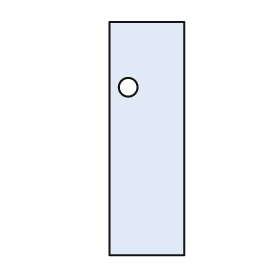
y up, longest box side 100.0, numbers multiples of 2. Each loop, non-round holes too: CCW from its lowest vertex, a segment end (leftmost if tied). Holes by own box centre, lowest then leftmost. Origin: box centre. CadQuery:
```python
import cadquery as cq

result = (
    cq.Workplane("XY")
    .moveTo(-16.0, -50.0)
    .lineTo(16.0, -50.0)
    .lineTo(16.0, 50.0)
    .lineTo(-16.0, 50.0)
    .close()
    .moveTo(-8.0, 22.0)
    .circle(4.0)
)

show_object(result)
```